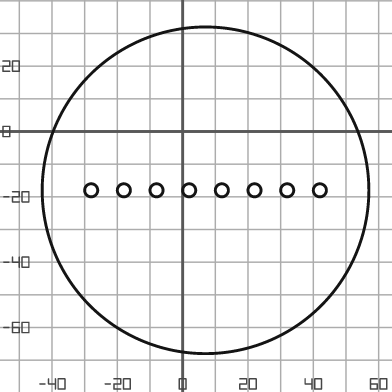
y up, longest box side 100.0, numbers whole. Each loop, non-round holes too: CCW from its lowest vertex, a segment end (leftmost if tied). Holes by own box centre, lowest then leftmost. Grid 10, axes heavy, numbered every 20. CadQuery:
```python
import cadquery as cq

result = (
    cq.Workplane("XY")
    .moveTo(7.0, -18.0)
    .circle(50.0)
    .moveTo(-28.0, -18.0)
    .circle(2.0)
    .moveTo(-18.0, -18.0)
    .circle(2.0)
    .moveTo(-8.0, -18.0)
    .circle(2.0)
    .moveTo(2.0, -18.0)
    .circle(2.0)
    .moveTo(12.0, -18.0)
    .circle(2.0)
    .moveTo(22.0, -18.0)
    .circle(2.0)
    .moveTo(32.0, -18.0)
    .circle(2.0)
    .moveTo(42.0, -18.0)
    .circle(2.0)
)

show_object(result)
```